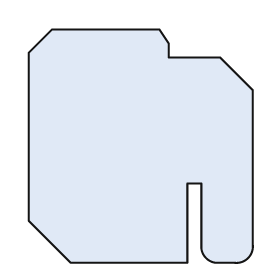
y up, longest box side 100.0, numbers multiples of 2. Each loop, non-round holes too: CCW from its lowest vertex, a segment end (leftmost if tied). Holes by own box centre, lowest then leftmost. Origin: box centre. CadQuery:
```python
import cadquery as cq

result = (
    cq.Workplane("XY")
    .moveTo(-30.0, -50.0)
    .lineTo(20.0, -50.0)
    .lineTo(20.0, -16.0)
    .lineTo(26.0, -16.0)
    .lineTo(26.0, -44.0)
    .threePointArc((28.0, -48.0), (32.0, -50.0))
    .lineTo(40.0, -50.0)
    .threePointArc((46.0, -48.0), (48.0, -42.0))
    .lineTo(48.0, 24.0)
    .lineTo(34.0, 38.0)
    .lineTo(12.0, 38.0)
    .lineTo(12.0, 44.0)
    .lineTo(8.0, 50.0)
    .lineTo(-38.0, 50.0)
    .lineTo(-48.0, 40.0)
    .lineTo(-48.0, -32.0)
    .close()
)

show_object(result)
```